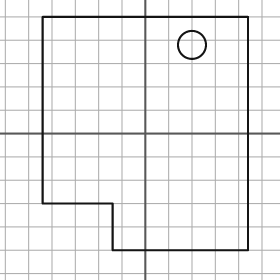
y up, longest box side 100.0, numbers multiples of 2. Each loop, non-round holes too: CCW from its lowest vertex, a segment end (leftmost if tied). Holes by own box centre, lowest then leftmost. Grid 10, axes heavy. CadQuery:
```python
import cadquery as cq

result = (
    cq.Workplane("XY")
    .moveTo(-14.0, -50.0)
    .lineTo(44.0, -50.0)
    .lineTo(44.0, 50.0)
    .lineTo(-44.0, 50.0)
    .lineTo(-44.0, -30.0)
    .lineTo(-14.0, -30.0)
    .close()
    .moveTo(20.0, 38.0)
    .circle(6.0)
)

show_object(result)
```